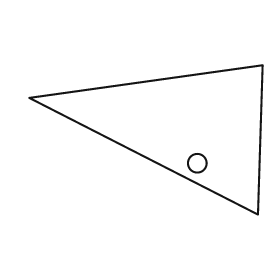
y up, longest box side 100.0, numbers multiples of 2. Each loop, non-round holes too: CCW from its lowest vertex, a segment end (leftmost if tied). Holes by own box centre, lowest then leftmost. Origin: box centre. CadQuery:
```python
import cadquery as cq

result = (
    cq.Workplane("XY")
    .moveTo(48.0, -32.0)
    .lineTo(50.0, 32.0)
    .lineTo(-50.0, 18.0)
    .close()
    .moveTo(22.0, -10.0)
    .circle(4.0)
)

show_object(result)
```